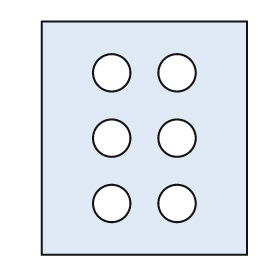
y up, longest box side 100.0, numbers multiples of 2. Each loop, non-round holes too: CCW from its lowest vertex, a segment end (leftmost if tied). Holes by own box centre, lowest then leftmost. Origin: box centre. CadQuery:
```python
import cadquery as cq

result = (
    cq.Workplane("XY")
    .moveTo(-44.0, -50.0)
    .lineTo(44.0, -50.0)
    .lineTo(44.0, 50.0)
    .lineTo(-44.0, 50.0)
    .close()
    .moveTo(-14.0, -28.0)
    .circle(8.0)
    .moveTo(14.0, -28.0)
    .circle(8.0)
    .moveTo(-14.0, 0.0)
    .circle(8.0)
    .moveTo(14.0, 0.0)
    .circle(8.0)
    .moveTo(-14.0, 28.0)
    .circle(8.0)
    .moveTo(14.0, 28.0)
    .circle(8.0)
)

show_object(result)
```